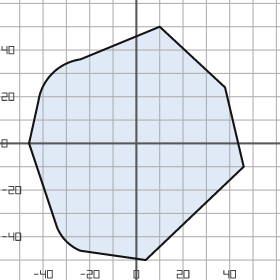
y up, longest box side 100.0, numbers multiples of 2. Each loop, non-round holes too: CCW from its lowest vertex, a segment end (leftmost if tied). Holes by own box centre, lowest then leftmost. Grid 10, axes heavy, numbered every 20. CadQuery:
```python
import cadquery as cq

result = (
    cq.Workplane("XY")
    .moveTo(4.0, -50.0)
    .lineTo(46.0, -10.0)
    .lineTo(38.0, 24.0)
    .lineTo(10.0, 50.0)
    .lineTo(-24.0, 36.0)
    .threePointArc((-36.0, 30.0), (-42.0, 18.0))
    .lineTo(-46.0, 0.0)
    .lineTo(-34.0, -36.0)
    .threePointArc((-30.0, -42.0), (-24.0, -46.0))
    .close()
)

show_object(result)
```